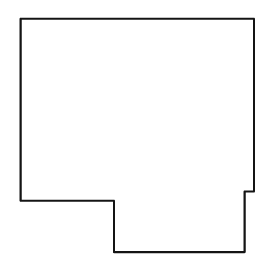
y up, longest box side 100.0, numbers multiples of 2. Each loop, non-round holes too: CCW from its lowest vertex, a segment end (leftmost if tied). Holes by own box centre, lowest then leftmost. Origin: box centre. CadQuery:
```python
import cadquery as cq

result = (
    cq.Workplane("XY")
    .moveTo(-10.0, -50.0)
    .lineTo(46.0, -50.0)
    .lineTo(46.0, -24.0)
    .lineTo(50.0, -24.0)
    .lineTo(50.0, 50.0)
    .lineTo(-50.0, 50.0)
    .lineTo(-50.0, -28.0)
    .lineTo(-10.0, -28.0)
    .close()
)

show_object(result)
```